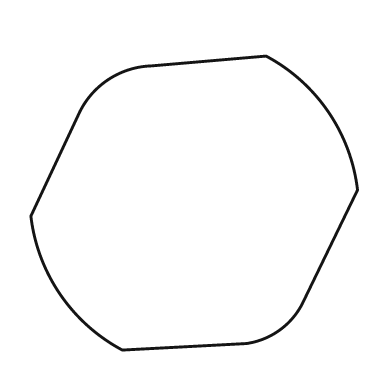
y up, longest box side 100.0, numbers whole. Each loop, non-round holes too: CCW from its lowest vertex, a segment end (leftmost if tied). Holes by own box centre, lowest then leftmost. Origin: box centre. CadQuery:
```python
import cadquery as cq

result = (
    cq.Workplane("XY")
    .moveTo(-22.0, -45.0)
    .lineTo(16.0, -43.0)
    .threePointArc((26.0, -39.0), (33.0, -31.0))
    .lineTo(50.0, 4.0)
    .threePointArc((41.0, 28.0), (22.0, 45.0))
    .lineTo(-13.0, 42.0)
    .threePointArc((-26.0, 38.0), (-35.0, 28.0))
    .lineTo(-50.0, -4.0)
    .threePointArc((-41.0, -28.0), (-22.0, -45.0))
    .close()
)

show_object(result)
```